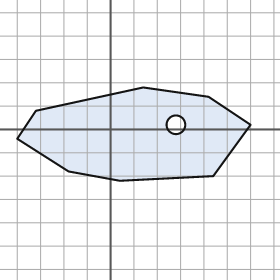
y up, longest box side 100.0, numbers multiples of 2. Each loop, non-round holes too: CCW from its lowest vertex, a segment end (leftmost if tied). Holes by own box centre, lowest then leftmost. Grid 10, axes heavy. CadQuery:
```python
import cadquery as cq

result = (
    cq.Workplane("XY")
    .moveTo(4.0, -22.0)
    .lineTo(44.0, -20.0)
    .lineTo(60.0, 2.0)
    .lineTo(42.0, 14.0)
    .lineTo(14.0, 18.0)
    .lineTo(-32.0, 8.0)
    .lineTo(-40.0, -4.0)
    .lineTo(-18.0, -18.0)
    .close()
    .moveTo(28.0, 2.0)
    .circle(4.0)
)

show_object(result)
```